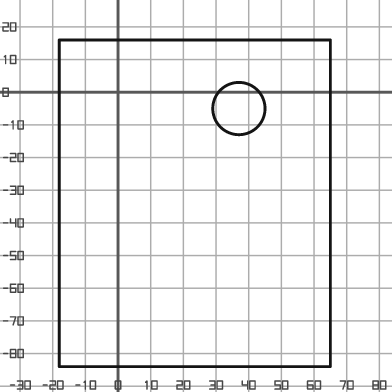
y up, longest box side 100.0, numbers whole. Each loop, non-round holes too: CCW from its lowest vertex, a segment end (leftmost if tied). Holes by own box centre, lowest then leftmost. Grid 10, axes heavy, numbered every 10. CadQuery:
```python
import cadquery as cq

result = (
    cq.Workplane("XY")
    .moveTo(-18.0, -84.0)
    .lineTo(65.0, -84.0)
    .lineTo(65.0, 16.0)
    .lineTo(-18.0, 16.0)
    .close()
    .moveTo(37.0, -5.0)
    .circle(8.0)
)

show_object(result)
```